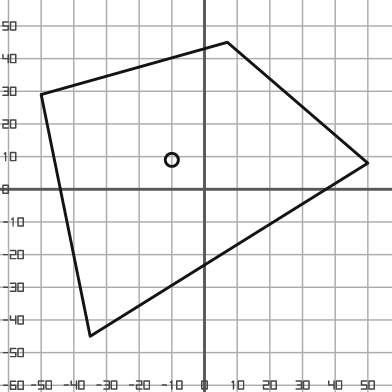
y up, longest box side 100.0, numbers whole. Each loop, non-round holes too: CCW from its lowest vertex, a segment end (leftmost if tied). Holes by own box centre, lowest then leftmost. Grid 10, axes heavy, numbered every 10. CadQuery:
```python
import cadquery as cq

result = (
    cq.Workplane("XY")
    .moveTo(-35.0, -45.0)
    .lineTo(50.0, 8.0)
    .lineTo(7.0, 45.0)
    .lineTo(-50.0, 29.0)
    .close()
    .moveTo(-10.0, 9.0)
    .circle(2.0)
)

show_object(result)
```